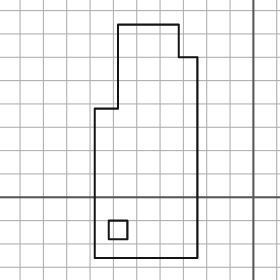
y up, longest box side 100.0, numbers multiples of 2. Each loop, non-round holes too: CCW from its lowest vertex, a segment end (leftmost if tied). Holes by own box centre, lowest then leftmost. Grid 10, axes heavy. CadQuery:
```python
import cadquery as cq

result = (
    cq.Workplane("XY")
    .moveTo(-68.0, -26.0)
    .lineTo(-24.0, -26.0)
    .lineTo(-24.0, 60.0)
    .lineTo(-32.0, 60.0)
    .lineTo(-32.0, 74.0)
    .lineTo(-58.0, 74.0)
    .lineTo(-58.0, 38.0)
    .lineTo(-68.0, 38.0)
    .close()
    .moveTo(-62.0, -18.0)
    .lineTo(-54.0, -18.0)
    .lineTo(-54.0, -10.0)
    .lineTo(-62.0, -10.0)
    .close()
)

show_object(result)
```